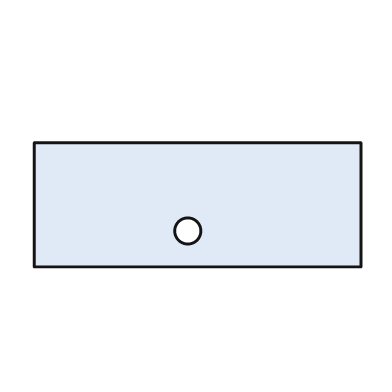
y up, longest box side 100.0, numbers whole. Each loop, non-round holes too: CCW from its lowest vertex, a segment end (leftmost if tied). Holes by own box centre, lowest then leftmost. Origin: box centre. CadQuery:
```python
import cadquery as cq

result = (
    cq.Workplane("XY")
    .moveTo(-50.0, -19.0)
    .lineTo(50.0, -19.0)
    .lineTo(50.0, 19.0)
    .lineTo(-50.0, 19.0)
    .close()
    .moveTo(-3.0, -8.0)
    .circle(4.0)
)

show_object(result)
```